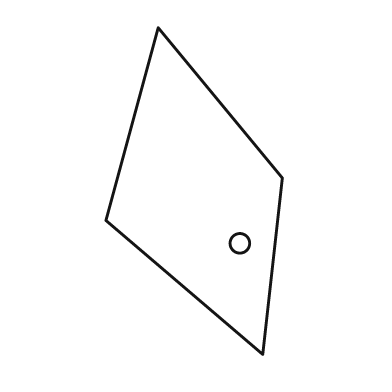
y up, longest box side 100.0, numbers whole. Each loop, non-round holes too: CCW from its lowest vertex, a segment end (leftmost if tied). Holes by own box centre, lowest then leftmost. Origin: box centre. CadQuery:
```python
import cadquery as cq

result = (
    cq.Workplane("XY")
    .moveTo(21.0, -50.0)
    .lineTo(27.0, 4.0)
    .lineTo(-11.0, 50.0)
    .lineTo(-27.0, -9.0)
    .close()
    .moveTo(14.0, -16.0)
    .circle(3.0)
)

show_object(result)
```